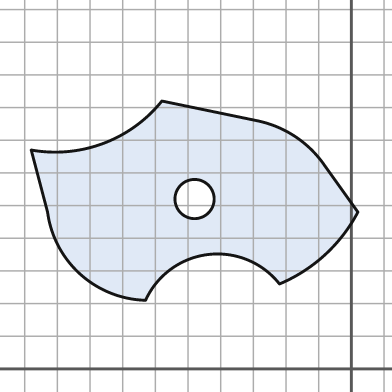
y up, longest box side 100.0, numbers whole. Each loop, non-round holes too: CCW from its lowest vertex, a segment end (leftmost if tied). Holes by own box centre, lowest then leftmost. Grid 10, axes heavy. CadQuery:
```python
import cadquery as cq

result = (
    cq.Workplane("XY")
    .moveTo(-63.0, 21.0)
    .threePointArc((-44.0, 35.0), (-22.0, 26.0))
    .threePointArc((-8.0, 35.0), (2.0, 48.0))
    .lineTo(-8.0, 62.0)
    .threePointArc((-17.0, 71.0), (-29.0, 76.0))
    .lineTo(-58.0, 82.0)
    .threePointArc((-76.0, 69.0), (-98.0, 67.0))
    .lineTo(-93.0, 48.0)
    .threePointArc((-83.0, 29.0), (-63.0, 21.0))
    .close()
    .moveTo(-48.0, 52.0)
    .circle(6.0)
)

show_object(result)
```